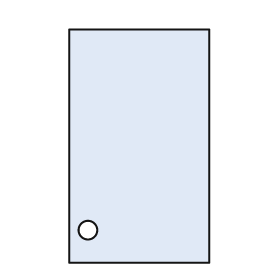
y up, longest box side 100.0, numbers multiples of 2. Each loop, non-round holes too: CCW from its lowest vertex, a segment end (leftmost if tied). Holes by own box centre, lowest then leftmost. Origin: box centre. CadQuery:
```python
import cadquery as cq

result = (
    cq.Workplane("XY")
    .moveTo(-30.0, -50.0)
    .lineTo(30.0, -50.0)
    .lineTo(30.0, 50.0)
    .lineTo(-30.0, 50.0)
    .close()
    .moveTo(-22.0, -36.0)
    .circle(4.0)
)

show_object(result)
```